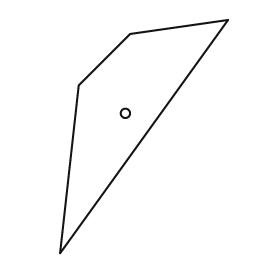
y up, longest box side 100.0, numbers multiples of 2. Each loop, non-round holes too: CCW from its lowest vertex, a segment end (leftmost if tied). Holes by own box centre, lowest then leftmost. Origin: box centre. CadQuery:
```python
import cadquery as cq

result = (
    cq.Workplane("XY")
    .moveTo(-36.0, -50.0)
    .lineTo(36.0, 50.0)
    .lineTo(-6.0, 44.0)
    .lineTo(-28.0, 22.0)
    .close()
    .moveTo(-8.0, 10.0)
    .circle(2.0)
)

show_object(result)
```